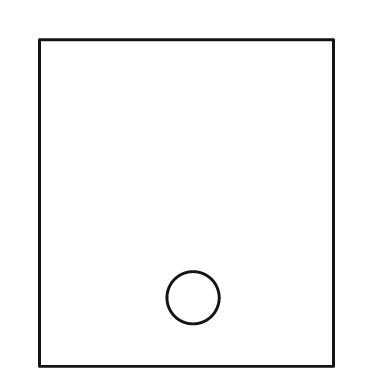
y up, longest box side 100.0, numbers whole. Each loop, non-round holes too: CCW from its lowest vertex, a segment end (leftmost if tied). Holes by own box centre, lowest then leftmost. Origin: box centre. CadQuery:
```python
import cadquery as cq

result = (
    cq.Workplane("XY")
    .moveTo(-45.0, -50.0)
    .lineTo(45.0, -50.0)
    .lineTo(45.0, 50.0)
    .lineTo(-45.0, 50.0)
    .close()
    .moveTo(2.0, -29.0)
    .circle(8.0)
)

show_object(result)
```